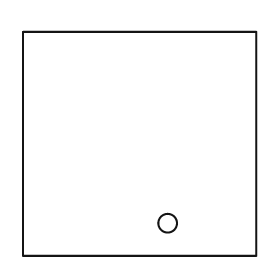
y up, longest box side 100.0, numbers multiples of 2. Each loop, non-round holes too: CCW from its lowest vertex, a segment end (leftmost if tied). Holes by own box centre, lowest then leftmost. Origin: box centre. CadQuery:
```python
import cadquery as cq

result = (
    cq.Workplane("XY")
    .moveTo(-50.0, -48.0)
    .lineTo(50.0, -48.0)
    .lineTo(50.0, 48.0)
    .lineTo(-50.0, 48.0)
    .close()
    .moveTo(12.0, -34.0)
    .circle(4.0)
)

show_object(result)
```